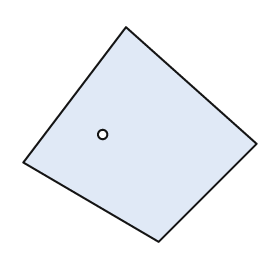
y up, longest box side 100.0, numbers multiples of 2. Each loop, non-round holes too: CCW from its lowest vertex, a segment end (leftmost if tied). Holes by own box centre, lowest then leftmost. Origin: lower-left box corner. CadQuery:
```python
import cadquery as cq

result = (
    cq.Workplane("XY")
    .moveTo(58.0, 0.0)
    .lineTo(100.0, 42.0)
    .lineTo(44.0, 92.0)
    .lineTo(0.0, 34.0)
    .close()
    .moveTo(34.0, 46.0)
    .circle(2.0)
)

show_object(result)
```